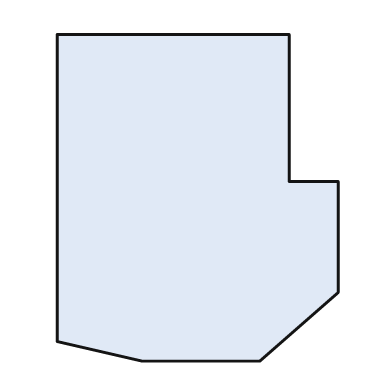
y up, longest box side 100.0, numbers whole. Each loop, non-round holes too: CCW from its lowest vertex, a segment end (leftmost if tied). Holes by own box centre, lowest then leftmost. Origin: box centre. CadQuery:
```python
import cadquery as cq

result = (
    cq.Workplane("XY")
    .moveTo(-17.0, -50.0)
    .lineTo(19.0, -50.0)
    .lineTo(43.0, -29.0)
    .lineTo(43.0, 5.0)
    .lineTo(28.0, 5.0)
    .lineTo(28.0, 50.0)
    .lineTo(-43.0, 50.0)
    .lineTo(-43.0, -44.0)
    .close()
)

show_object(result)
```